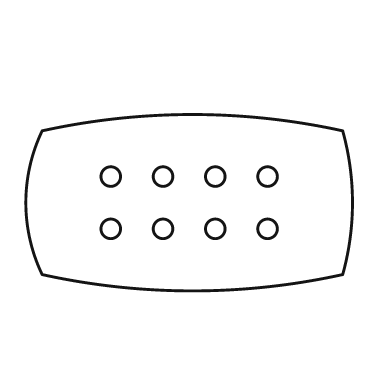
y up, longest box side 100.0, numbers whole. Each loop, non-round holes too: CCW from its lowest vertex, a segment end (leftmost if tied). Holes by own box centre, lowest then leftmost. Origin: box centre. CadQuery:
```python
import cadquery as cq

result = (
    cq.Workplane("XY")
    .moveTo(-45.0, -22.0)
    .threePointArc((1.0, -27.0), (47.0, -22.0))
    .threePointArc((50.0, 0.0), (47.0, 22.0))
    .threePointArc((1.0, 27.0), (-45.0, 22.0))
    .threePointArc((-50.0, 0.0), (-45.0, -22.0))
    .close()
    .moveTo(-24.0, -8.0)
    .circle(3.0)
    .moveTo(-8.0, -8.0)
    .circle(3.0)
    .moveTo(8.0, -8.0)
    .circle(3.0)
    .moveTo(24.0, -8.0)
    .circle(3.0)
    .moveTo(-24.0, 8.0)
    .circle(3.0)
    .moveTo(-8.0, 8.0)
    .circle(3.0)
    .moveTo(8.0, 8.0)
    .circle(3.0)
    .moveTo(24.0, 8.0)
    .circle(3.0)
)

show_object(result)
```